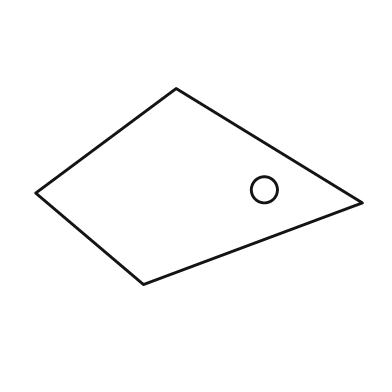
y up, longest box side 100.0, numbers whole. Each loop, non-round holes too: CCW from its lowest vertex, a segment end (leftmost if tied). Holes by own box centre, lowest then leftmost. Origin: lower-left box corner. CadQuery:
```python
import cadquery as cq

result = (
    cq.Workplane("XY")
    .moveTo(33.0, 0.0)
    .lineTo(100.0, 25.0)
    .lineTo(43.0, 60.0)
    .lineTo(0.0, 28.0)
    .close()
    .moveTo(70.0, 29.0)
    .circle(4.0)
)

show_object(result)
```